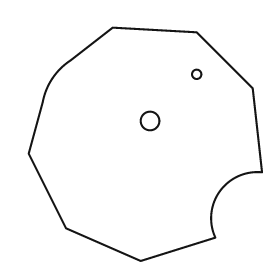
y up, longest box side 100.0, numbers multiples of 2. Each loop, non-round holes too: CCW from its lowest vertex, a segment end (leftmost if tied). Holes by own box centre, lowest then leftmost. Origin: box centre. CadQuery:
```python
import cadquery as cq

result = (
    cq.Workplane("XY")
    .moveTo(-2.0, -50.0)
    .lineTo(30.0, -40.0)
    .threePointArc((32.0, -20.0), (50.0, -12.0))
    .lineTo(46.0, 24.0)
    .lineTo(22.0, 48.0)
    .lineTo(-14.0, 50.0)
    .lineTo(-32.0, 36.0)
    .threePointArc((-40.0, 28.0), (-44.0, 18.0))
    .lineTo(-50.0, -4.0)
    .lineTo(-34.0, -36.0)
    .close()
    .moveTo(2.0, 10.0)
    .circle(4.0)
    .moveTo(22.0, 30.0)
    .circle(2.0)
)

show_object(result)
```